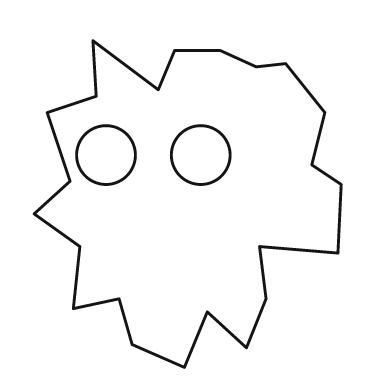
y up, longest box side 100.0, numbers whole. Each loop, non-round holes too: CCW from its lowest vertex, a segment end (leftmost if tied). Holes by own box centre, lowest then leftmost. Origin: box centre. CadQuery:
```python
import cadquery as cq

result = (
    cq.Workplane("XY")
    .moveTo(-1.0, -50.0)
    .lineTo(6.0, -33.0)
    .lineTo(18.0, -44.0)
    .lineTo(24.0, -29.0)
    .lineTo(22.0, -13.0)
    .lineTo(46.0, -15.0)
    .lineTo(47.0, 6.0)
    .lineTo(38.0, 12.0)
    .lineTo(42.0, 28.0)
    .lineTo(30.0, 43.0)
    .lineTo(21.0, 42.0)
    .lineTo(10.0, 47.0)
    .lineTo(-4.0, 47.0)
    .lineTo(-9.0, 35.0)
    .lineTo(-29.0, 50.0)
    .lineTo(-28.0, 33.0)
    .lineTo(-43.0, 28.0)
    .lineTo(-36.0, 7.0)
    .lineTo(-47.0, -3.0)
    .lineTo(-33.0, -13.0)
    .lineTo(-35.0, -32.0)
    .lineTo(-21.0, -29.0)
    .lineTo(-17.0, -43.0)
    .close()
    .moveTo(-25.0, 15.0)
    .circle(9.0)
    .moveTo(4.0, 15.0)
    .circle(9.0)
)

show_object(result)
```